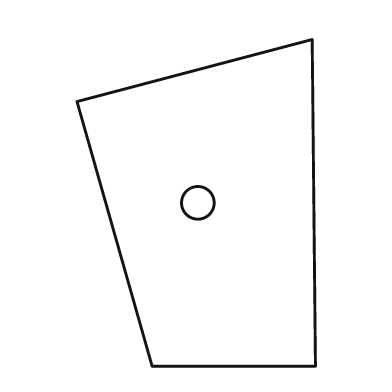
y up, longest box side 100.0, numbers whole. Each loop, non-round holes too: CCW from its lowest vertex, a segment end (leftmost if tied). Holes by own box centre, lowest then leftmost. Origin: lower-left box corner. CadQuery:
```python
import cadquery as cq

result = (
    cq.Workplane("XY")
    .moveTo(23.0, 0.0)
    .lineTo(73.0, 0.0)
    .lineTo(72.0, 100.0)
    .lineTo(0.0, 81.0)
    .close()
    .moveTo(37.0, 50.0)
    .circle(5.0)
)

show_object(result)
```